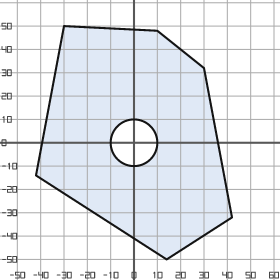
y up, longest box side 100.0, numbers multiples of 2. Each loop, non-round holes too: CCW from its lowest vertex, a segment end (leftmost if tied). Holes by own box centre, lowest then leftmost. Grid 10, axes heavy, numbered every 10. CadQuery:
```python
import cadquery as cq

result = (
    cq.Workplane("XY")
    .moveTo(14.0, -50.0)
    .lineTo(42.0, -32.0)
    .lineTo(30.0, 32.0)
    .lineTo(10.0, 48.0)
    .lineTo(-30.0, 50.0)
    .lineTo(-42.0, -14.0)
    .close()
    .moveTo(0.0, 0.0)
    .circle(10.0)
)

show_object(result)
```